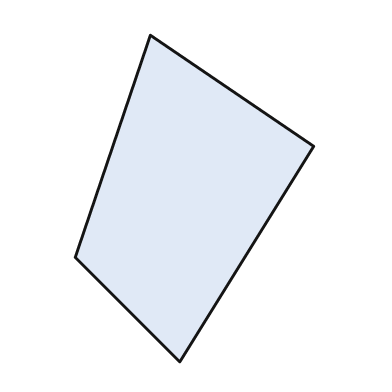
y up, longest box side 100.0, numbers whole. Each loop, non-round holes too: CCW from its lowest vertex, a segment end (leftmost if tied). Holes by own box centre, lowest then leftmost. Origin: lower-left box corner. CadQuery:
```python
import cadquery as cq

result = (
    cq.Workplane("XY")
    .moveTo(32.0, 0.0)
    .lineTo(73.0, 66.0)
    .lineTo(23.0, 100.0)
    .lineTo(0.0, 32.0)
    .close()
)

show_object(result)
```